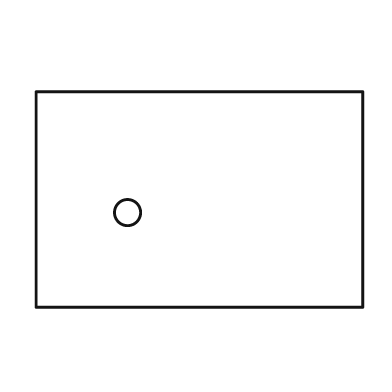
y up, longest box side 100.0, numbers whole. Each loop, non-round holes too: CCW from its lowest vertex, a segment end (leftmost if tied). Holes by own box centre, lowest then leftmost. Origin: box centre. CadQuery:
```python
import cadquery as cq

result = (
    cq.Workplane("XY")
    .moveTo(-50.0, -33.0)
    .lineTo(50.0, -33.0)
    .lineTo(50.0, 33.0)
    .lineTo(-50.0, 33.0)
    .close()
    .moveTo(-22.0, -4.0)
    .circle(4.0)
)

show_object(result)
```